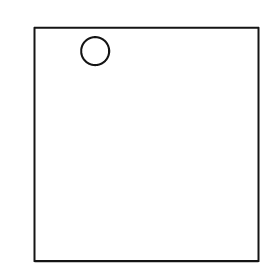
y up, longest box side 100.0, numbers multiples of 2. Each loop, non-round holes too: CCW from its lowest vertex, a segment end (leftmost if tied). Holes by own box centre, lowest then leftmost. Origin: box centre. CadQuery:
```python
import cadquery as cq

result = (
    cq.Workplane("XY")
    .moveTo(-48.0, -50.0)
    .lineTo(48.0, -50.0)
    .lineTo(48.0, 50.0)
    .lineTo(-48.0, 50.0)
    .close()
    .moveTo(-22.0, 40.0)
    .circle(6.0)
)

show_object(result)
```